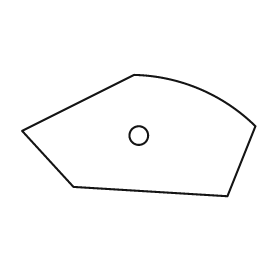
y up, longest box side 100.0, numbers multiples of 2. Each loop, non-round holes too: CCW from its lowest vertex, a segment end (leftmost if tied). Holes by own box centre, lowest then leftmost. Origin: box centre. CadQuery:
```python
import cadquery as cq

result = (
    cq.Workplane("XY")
    .moveTo(38.0, -26.0)
    .lineTo(50.0, 4.0)
    .threePointArc((26.0, 20.0), (-2.0, 26.0))
    .lineTo(-50.0, 2.0)
    .lineTo(-28.0, -22.0)
    .close()
    .moveTo(0.0, 0.0)
    .circle(4.0)
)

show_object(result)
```